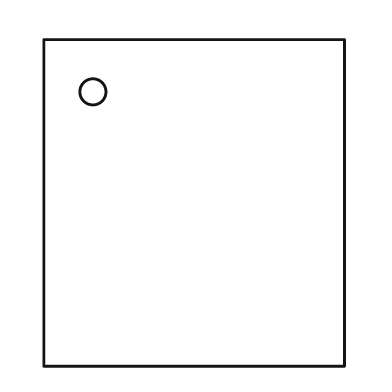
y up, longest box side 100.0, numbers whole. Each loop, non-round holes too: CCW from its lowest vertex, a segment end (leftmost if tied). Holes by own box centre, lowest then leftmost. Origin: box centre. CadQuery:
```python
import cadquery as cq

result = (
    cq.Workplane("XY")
    .moveTo(-46.0, -50.0)
    .lineTo(46.0, -50.0)
    .lineTo(46.0, 50.0)
    .lineTo(-46.0, 50.0)
    .close()
    .moveTo(-31.0, 34.0)
    .circle(4.0)
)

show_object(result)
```